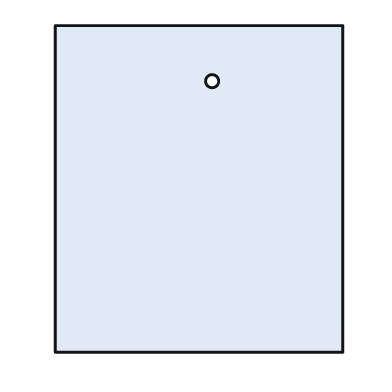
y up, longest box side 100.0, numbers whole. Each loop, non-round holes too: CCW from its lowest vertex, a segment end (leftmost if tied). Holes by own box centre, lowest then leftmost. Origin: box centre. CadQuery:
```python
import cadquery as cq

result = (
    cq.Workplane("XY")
    .moveTo(-44.0, -50.0)
    .lineTo(44.0, -50.0)
    .lineTo(44.0, 50.0)
    .lineTo(-44.0, 50.0)
    .close()
    .moveTo(4.0, 33.0)
    .circle(2.0)
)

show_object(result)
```